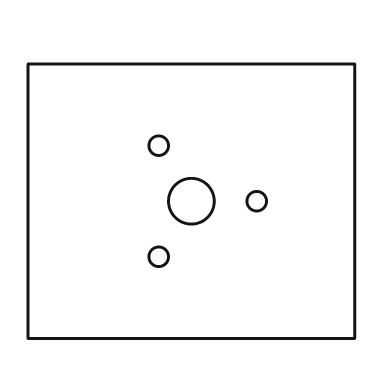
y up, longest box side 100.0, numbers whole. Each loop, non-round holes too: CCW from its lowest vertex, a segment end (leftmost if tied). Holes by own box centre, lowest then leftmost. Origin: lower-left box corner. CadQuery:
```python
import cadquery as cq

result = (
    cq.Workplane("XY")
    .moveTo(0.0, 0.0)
    .lineTo(100.0, 0.0)
    .lineTo(100.0, 84.0)
    .lineTo(0.0, 84.0)
    .close()
    .moveTo(40.0, 25.0)
    .circle(3.0)
    .moveTo(50.0, 42.0)
    .circle(7.0)
    .moveTo(70.0, 42.0)
    .circle(3.0)
    .moveTo(40.0, 59.0)
    .circle(3.0)
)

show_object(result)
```